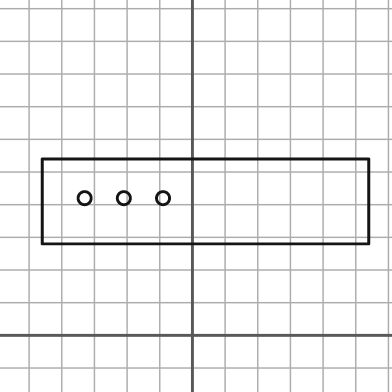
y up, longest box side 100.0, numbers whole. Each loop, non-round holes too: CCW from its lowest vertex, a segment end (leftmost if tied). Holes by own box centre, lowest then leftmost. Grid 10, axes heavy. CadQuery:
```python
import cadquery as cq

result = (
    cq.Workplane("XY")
    .moveTo(-46.0, 28.0)
    .lineTo(54.0, 28.0)
    .lineTo(54.0, 54.0)
    .lineTo(-46.0, 54.0)
    .close()
    .moveTo(-33.0, 42.0)
    .circle(2.0)
    .moveTo(-21.0, 42.0)
    .circle(2.0)
    .moveTo(-9.0, 42.0)
    .circle(2.0)
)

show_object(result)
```